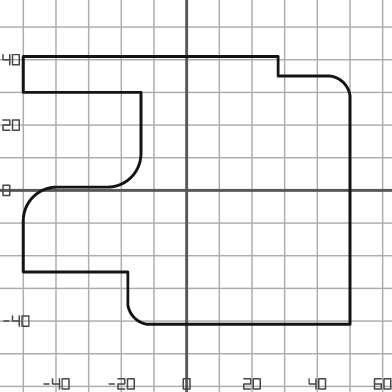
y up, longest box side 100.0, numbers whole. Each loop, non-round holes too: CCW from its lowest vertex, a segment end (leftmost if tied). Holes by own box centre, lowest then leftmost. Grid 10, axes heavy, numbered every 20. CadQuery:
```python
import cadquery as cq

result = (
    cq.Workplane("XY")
    .moveTo(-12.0, -41.0)
    .lineTo(50.0, -41.0)
    .lineTo(50.0, 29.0)
    .threePointArc((48.0, 33.0), (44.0, 35.0))
    .lineTo(28.0, 35.0)
    .lineTo(28.0, 41.0)
    .lineTo(-50.0, 41.0)
    .lineTo(-50.0, 30.0)
    .lineTo(-14.0, 30.0)
    .lineTo(-14.0, 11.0)
    .threePointArc((-17.0, 4.0), (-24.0, 1.0))
    .lineTo(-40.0, 1.0)
    .threePointArc((-47.0, -2.0), (-50.0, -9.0))
    .lineTo(-50.0, -25.0)
    .lineTo(-18.0, -25.0)
    .lineTo(-18.0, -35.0)
    .threePointArc((-16.0, -39.0), (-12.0, -41.0))
    .close()
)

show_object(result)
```